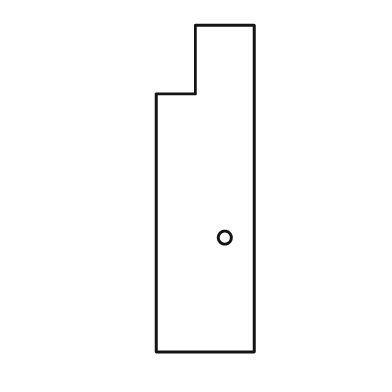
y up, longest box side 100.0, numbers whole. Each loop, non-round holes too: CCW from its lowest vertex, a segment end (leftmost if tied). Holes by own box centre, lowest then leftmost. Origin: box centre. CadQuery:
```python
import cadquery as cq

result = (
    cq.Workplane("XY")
    .moveTo(-15.0, -50.0)
    .lineTo(15.0, -50.0)
    .lineTo(15.0, 50.0)
    .lineTo(-3.0, 50.0)
    .lineTo(-3.0, 29.0)
    .lineTo(-15.0, 29.0)
    .close()
    .moveTo(6.0, -15.0)
    .circle(2.0)
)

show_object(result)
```